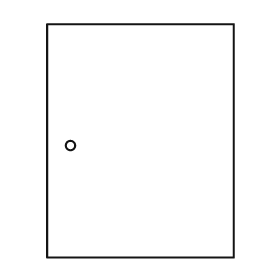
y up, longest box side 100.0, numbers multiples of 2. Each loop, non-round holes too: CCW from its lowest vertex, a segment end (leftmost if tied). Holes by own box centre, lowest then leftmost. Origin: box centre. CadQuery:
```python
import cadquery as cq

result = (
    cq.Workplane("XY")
    .moveTo(-40.0, -50.0)
    .lineTo(40.0, -50.0)
    .lineTo(40.0, 50.0)
    .lineTo(-40.0, 50.0)
    .close()
    .moveTo(-30.0, -2.0)
    .circle(2.0)
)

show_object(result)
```